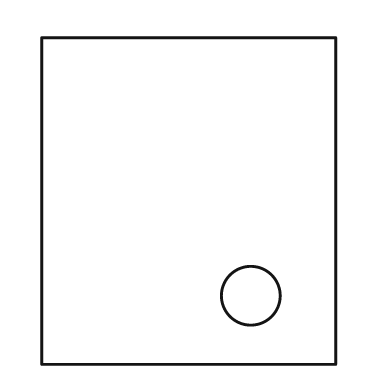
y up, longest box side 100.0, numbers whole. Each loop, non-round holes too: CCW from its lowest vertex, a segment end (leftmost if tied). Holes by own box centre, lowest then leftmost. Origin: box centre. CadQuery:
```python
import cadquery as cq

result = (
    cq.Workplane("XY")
    .moveTo(-45.0, -50.0)
    .lineTo(45.0, -50.0)
    .lineTo(45.0, 50.0)
    .lineTo(-45.0, 50.0)
    .close()
    .moveTo(19.0, -29.0)
    .circle(9.0)
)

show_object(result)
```